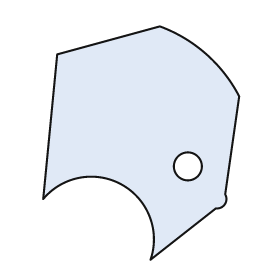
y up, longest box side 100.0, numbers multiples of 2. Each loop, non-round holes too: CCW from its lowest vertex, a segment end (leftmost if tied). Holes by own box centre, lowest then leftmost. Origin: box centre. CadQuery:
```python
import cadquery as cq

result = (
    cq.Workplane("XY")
    .moveTo(4.0, -50.0)
    .lineTo(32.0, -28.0)
    .threePointArc((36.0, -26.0), (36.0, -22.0))
    .lineTo(42.0, 20.0)
    .threePointArc((28.0, 38.0), (8.0, 50.0))
    .lineTo(-36.0, 38.0)
    .lineTo(-42.0, -24.0)
    .threePointArc((-8.0, -18.0), (4.0, -50.0))
    .close()
    .moveTo(20.0, -10.0)
    .circle(6.0)
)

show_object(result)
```